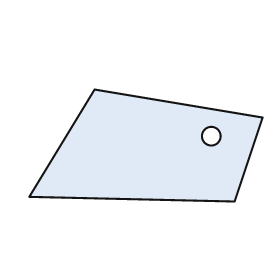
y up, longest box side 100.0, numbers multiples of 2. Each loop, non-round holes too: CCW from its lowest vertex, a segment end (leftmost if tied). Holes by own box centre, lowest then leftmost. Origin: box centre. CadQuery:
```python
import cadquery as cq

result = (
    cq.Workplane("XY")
    .moveTo(38.0, -24.0)
    .lineTo(50.0, 12.0)
    .lineTo(-22.0, 24.0)
    .lineTo(-50.0, -22.0)
    .close()
    .moveTo(28.0, 4.0)
    .circle(4.0)
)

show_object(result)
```